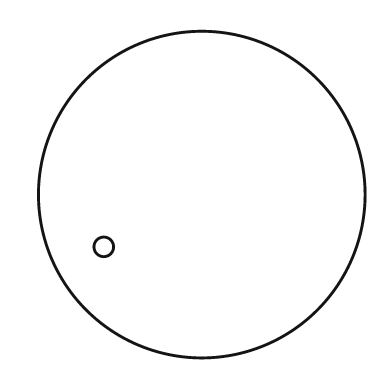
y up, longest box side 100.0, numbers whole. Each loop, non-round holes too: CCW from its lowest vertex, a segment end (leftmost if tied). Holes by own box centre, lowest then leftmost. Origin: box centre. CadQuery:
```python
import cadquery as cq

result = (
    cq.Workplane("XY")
    .moveTo(0.0, 0.0)
    .circle(50.0)
    .moveTo(-30.0, -16.0)
    .circle(3.0)
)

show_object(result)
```